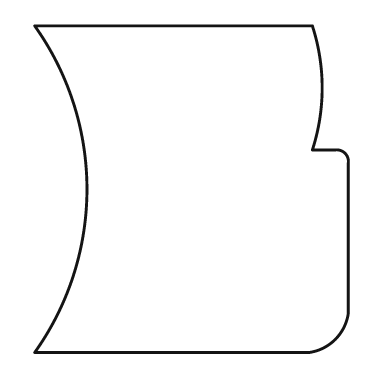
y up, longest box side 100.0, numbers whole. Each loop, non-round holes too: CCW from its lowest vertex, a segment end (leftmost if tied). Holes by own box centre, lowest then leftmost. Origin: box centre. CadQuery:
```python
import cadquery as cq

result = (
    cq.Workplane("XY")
    .moveTo(-48.0, -50.0)
    .lineTo(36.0, -50.0)
    .threePointArc((44.0, -46.0), (48.0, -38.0))
    .lineTo(48.0, 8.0)
    .threePointArc((47.0, 11.0), (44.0, 12.0))
    .lineTo(37.0, 12.0)
    .threePointArc((40.0, 31.0), (37.0, 50.0))
    .lineTo(-48.0, 50.0)
    .threePointArc((-32.0, 0.0), (-48.0, -50.0))
    .close()
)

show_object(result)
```